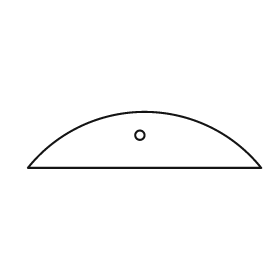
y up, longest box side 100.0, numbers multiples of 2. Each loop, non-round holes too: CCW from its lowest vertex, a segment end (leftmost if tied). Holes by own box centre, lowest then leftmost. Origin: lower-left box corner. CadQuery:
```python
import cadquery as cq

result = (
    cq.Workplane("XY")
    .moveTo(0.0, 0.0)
    .lineTo(100.0, 0.0)
    .threePointArc((50.0, 24.0), (0.0, 0.0))
    .close()
    .moveTo(48.0, 14.0)
    .circle(2.0)
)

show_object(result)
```